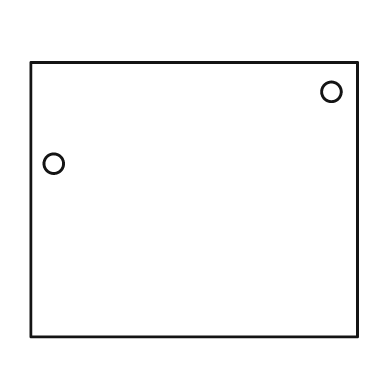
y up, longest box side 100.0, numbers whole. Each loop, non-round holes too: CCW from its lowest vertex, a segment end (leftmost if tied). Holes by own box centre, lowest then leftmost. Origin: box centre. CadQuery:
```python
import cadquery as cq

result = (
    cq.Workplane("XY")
    .moveTo(-50.0, -42.0)
    .lineTo(50.0, -42.0)
    .lineTo(50.0, 42.0)
    .lineTo(-50.0, 42.0)
    .close()
    .moveTo(-43.0, 11.0)
    .circle(3.0)
    .moveTo(42.0, 33.0)
    .circle(3.0)
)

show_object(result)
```